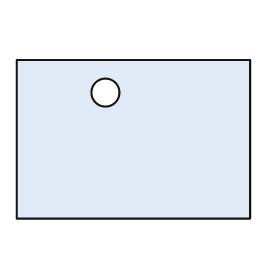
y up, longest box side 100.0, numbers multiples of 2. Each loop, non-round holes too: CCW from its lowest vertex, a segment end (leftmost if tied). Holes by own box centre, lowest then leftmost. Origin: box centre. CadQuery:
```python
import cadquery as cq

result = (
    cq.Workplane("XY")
    .moveTo(-50.0, -34.0)
    .lineTo(50.0, -34.0)
    .lineTo(50.0, 34.0)
    .lineTo(-50.0, 34.0)
    .close()
    .moveTo(-12.0, 20.0)
    .circle(6.0)
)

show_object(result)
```